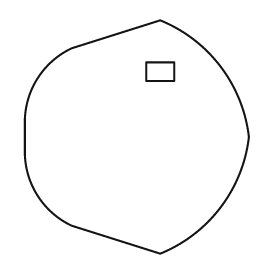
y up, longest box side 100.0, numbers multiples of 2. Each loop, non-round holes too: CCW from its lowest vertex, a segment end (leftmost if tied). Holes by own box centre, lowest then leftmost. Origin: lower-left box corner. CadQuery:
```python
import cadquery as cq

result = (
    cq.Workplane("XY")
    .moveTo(58.0, 0.0)
    .threePointArc((84.0, 20.0), (96.0, 50.0))
    .threePointArc((84.0, 80.0), (58.0, 100.0))
    .lineTo(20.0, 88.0)
    .threePointArc((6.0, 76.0), (0.0, 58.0))
    .lineTo(0.0, 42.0)
    .threePointArc((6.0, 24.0), (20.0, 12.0))
    .close()
    .moveTo(52.0, 74.0)
    .lineTo(64.0, 74.0)
    .lineTo(64.0, 82.0)
    .lineTo(52.0, 82.0)
    .close()
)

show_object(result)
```